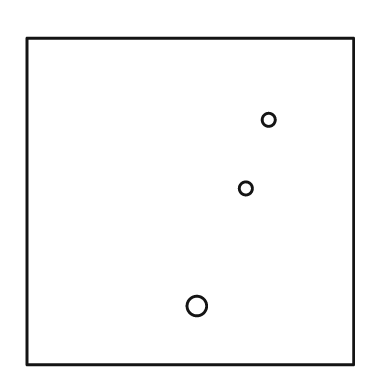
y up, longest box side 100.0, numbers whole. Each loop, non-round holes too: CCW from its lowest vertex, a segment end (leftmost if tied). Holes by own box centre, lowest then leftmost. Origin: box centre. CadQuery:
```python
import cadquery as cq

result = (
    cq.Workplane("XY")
    .moveTo(-50.0, -50.0)
    .lineTo(50.0, -50.0)
    .lineTo(50.0, 50.0)
    .lineTo(-50.0, 50.0)
    .close()
    .moveTo(2.0, -32.0)
    .circle(3.0)
    .moveTo(17.0, 4.0)
    .circle(2.0)
    .moveTo(24.0, 25.0)
    .circle(2.0)
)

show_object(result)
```